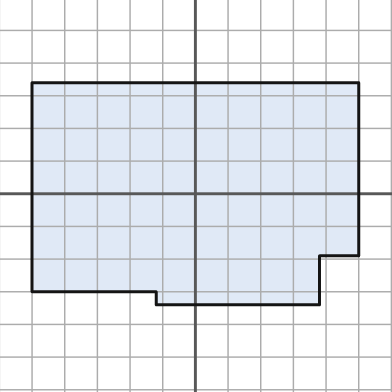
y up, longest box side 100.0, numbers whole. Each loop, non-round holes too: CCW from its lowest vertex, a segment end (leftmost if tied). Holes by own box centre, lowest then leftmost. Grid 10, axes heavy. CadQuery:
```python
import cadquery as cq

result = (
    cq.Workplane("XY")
    .moveTo(-12.0, -34.0)
    .lineTo(38.0, -34.0)
    .lineTo(38.0, -19.0)
    .lineTo(50.0, -19.0)
    .lineTo(50.0, 34.0)
    .lineTo(-50.0, 34.0)
    .lineTo(-50.0, -30.0)
    .lineTo(-12.0, -30.0)
    .close()
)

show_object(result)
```